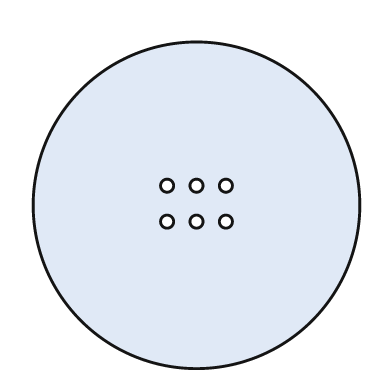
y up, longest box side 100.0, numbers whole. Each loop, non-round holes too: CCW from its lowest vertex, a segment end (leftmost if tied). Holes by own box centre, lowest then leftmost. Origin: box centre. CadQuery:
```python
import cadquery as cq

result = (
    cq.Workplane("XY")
    .moveTo(0.0, 0.0)
    .circle(50.0)
    .moveTo(-9.0, -5.0)
    .circle(2.0)
    .moveTo(0.0, -5.0)
    .circle(2.0)
    .moveTo(9.0, -5.0)
    .circle(2.0)
    .moveTo(-9.0, 6.0)
    .circle(2.0)
    .moveTo(0.0, 6.0)
    .circle(2.0)
    .moveTo(9.0, 6.0)
    .circle(2.0)
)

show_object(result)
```